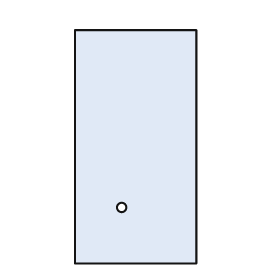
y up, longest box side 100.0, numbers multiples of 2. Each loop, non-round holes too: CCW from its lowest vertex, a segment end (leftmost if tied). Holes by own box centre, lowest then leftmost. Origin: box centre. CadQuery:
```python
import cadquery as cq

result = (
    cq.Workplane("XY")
    .moveTo(-26.0, -50.0)
    .lineTo(26.0, -50.0)
    .lineTo(26.0, 50.0)
    .lineTo(-26.0, 50.0)
    .close()
    .moveTo(-6.0, -26.0)
    .circle(2.0)
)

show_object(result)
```